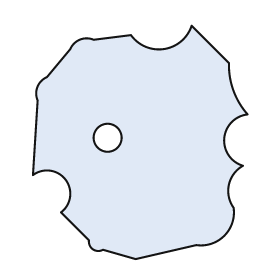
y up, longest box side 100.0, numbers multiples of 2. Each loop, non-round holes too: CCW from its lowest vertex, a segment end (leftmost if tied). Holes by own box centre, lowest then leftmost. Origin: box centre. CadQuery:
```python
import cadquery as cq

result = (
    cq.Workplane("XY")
    .moveTo(-2.0, -50.0)
    .lineTo(24.0, -44.0)
    .threePointArc((36.0, -40.0), (40.0, -28.0))
    .threePointArc((38.0, -18.0), (44.0, -10.0))
    .threePointArc((36.0, 2.0), (46.0, 12.0))
    .threePointArc((40.0, 22.0), (38.0, 34.0))
    .lineTo(22.0, 50.0)
    .threePointArc((10.0, 40.0), (-4.0, 46.0))
    .lineTo(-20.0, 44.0)
    .threePointArc((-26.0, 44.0), (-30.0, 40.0))
    .lineTo(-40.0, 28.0)
    .threePointArc((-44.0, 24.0), (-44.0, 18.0))
    .lineTo(-46.0, -14.0)
    .threePointArc((-32.0, -16.0), (-34.0, -30.0))
    .lineTo(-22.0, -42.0)
    .threePointArc((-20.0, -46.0), (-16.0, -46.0))
    .close()
    .moveTo(-14.0, 2.0)
    .circle(6.0)
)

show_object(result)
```